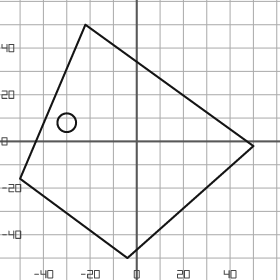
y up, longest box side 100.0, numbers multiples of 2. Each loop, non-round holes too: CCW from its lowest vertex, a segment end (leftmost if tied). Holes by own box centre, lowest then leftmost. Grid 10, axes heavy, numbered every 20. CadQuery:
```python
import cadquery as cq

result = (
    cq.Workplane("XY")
    .moveTo(-4.0, -50.0)
    .lineTo(50.0, -2.0)
    .lineTo(-22.0, 50.0)
    .lineTo(-50.0, -16.0)
    .close()
    .moveTo(-30.0, 8.0)
    .circle(4.0)
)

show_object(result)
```